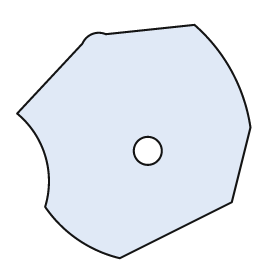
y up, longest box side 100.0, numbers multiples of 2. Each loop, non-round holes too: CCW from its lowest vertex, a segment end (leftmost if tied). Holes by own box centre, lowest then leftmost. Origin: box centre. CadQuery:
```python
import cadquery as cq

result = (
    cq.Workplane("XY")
    .moveTo(-6.0, -50.0)
    .lineTo(42.0, -26.0)
    .lineTo(50.0, 6.0)
    .threePointArc((42.0, 30.0), (26.0, 50.0))
    .lineTo(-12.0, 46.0)
    .threePointArc((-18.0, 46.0), (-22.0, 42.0))
    .lineTo(-50.0, 12.0)
    .threePointArc((-38.0, -6.0), (-38.0, -28.0))
    .threePointArc((-24.0, -42.0), (-6.0, -50.0))
    .close()
    .moveTo(6.0, -4.0)
    .circle(6.0)
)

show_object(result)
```